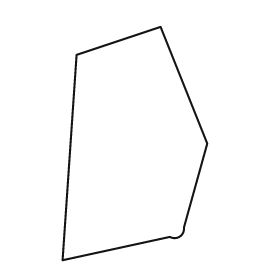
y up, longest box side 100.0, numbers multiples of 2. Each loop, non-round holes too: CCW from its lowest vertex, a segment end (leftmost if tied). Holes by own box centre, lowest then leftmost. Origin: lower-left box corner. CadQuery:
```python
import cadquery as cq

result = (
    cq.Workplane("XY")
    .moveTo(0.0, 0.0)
    .lineTo(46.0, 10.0)
    .threePointArc((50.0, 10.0), (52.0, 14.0))
    .lineTo(62.0, 50.0)
    .lineTo(42.0, 100.0)
    .lineTo(6.0, 88.0)
    .close()
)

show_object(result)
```